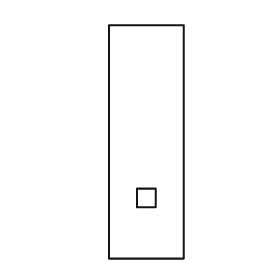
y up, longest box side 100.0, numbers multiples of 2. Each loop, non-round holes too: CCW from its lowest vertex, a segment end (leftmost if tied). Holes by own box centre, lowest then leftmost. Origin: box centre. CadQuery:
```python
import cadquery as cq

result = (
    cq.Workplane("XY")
    .moveTo(-16.0, -50.0)
    .lineTo(16.0, -50.0)
    .lineTo(16.0, 50.0)
    .lineTo(-16.0, 50.0)
    .close()
    .moveTo(-4.0, -28.0)
    .lineTo(4.0, -28.0)
    .lineTo(4.0, -20.0)
    .lineTo(-4.0, -20.0)
    .close()
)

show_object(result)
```